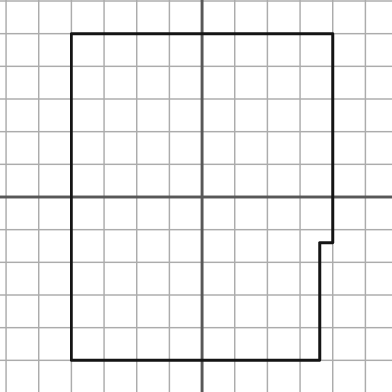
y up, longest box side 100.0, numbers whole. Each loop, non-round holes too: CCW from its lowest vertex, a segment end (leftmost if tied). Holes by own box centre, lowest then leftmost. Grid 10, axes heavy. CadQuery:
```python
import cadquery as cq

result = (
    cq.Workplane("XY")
    .moveTo(-40.0, -50.0)
    .lineTo(36.0, -50.0)
    .lineTo(36.0, -14.0)
    .lineTo(40.0, -14.0)
    .lineTo(40.0, 50.0)
    .lineTo(-40.0, 50.0)
    .close()
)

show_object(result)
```